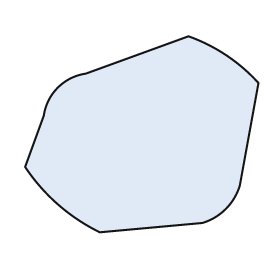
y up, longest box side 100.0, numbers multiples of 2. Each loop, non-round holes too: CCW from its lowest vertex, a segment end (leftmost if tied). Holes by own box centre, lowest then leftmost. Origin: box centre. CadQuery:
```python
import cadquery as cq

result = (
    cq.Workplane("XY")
    .moveTo(-18.0, -42.0)
    .lineTo(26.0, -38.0)
    .threePointArc((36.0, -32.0), (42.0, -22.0))
    .lineTo(50.0, 22.0)
    .threePointArc((36.0, 34.0), (20.0, 42.0))
    .lineTo(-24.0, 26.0)
    .threePointArc((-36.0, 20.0), (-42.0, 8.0))
    .lineTo(-50.0, -14.0)
    .threePointArc((-36.0, -30.0), (-18.0, -42.0))
    .close()
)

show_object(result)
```